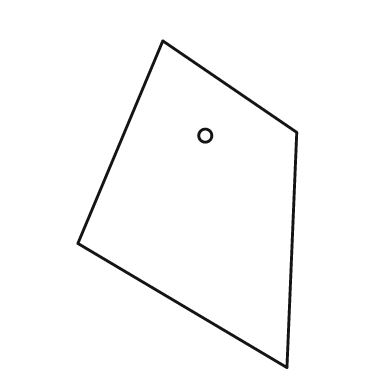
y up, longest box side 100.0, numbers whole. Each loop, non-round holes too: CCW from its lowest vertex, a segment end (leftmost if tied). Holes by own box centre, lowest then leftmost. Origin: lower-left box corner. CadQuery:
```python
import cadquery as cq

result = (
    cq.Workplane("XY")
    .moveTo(64.0, 0.0)
    .lineTo(67.0, 72.0)
    .lineTo(26.0, 100.0)
    .lineTo(0.0, 38.0)
    .close()
    .moveTo(39.0, 71.0)
    .circle(2.0)
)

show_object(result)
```